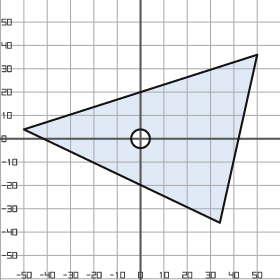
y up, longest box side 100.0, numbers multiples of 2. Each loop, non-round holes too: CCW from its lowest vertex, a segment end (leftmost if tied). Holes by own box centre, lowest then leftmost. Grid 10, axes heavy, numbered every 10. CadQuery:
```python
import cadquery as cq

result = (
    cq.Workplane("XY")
    .moveTo(34.0, -36.0)
    .lineTo(50.0, 36.0)
    .lineTo(-50.0, 4.0)
    .close()
    .moveTo(0.0, 0.0)
    .circle(4.0)
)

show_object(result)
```